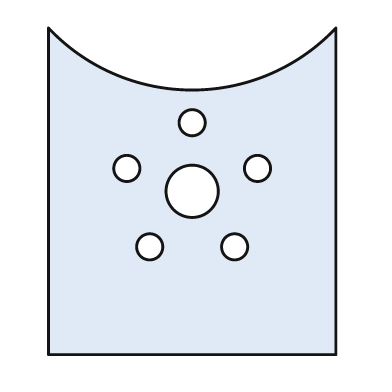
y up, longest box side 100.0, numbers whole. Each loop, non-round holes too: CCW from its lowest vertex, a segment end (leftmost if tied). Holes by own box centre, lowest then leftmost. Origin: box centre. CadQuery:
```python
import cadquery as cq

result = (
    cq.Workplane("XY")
    .moveTo(-44.0, -50.0)
    .lineTo(44.0, -50.0)
    .lineTo(44.0, 50.0)
    .threePointArc((0.0, 31.0), (-44.0, 50.0))
    .close()
    .moveTo(-13.0, -17.0)
    .circle(4.0)
    .moveTo(13.0, -17.0)
    .circle(4.0)
    .moveTo(0.0, 0.0)
    .circle(8.0)
    .moveTo(-20.0, 7.0)
    .circle(4.0)
    .moveTo(20.0, 7.0)
    .circle(4.0)
    .moveTo(0.0, 21.0)
    .circle(4.0)
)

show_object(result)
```